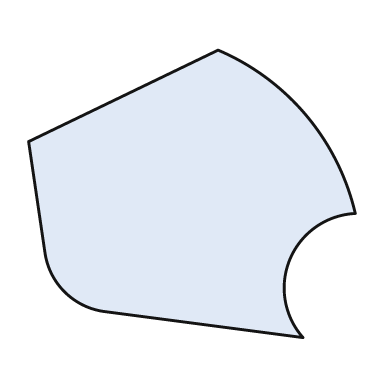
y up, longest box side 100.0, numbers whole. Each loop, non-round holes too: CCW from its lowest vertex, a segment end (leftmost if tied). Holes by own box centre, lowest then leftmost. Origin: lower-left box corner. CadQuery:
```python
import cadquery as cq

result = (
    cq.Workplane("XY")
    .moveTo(84.0, 0.0)
    .threePointArc((80.0, 24.0), (100.0, 38.0))
    .threePointArc((85.0, 68.0), (58.0, 88.0))
    .lineTo(0.0, 60.0)
    .lineTo(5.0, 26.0)
    .threePointArc((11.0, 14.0), (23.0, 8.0))
    .close()
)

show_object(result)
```